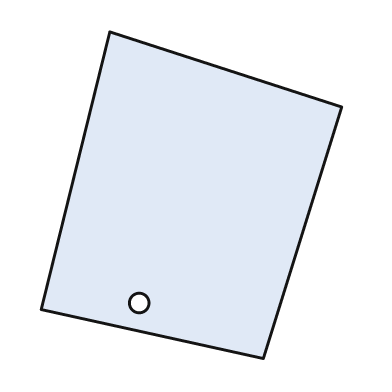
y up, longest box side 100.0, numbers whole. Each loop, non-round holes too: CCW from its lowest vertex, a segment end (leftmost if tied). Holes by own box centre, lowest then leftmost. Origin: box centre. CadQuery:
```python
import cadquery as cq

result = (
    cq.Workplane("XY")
    .moveTo(22.0, -50.0)
    .lineTo(46.0, 27.0)
    .lineTo(-25.0, 50.0)
    .lineTo(-46.0, -35.0)
    .close()
    .moveTo(-16.0, -33.0)
    .circle(3.0)
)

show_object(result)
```